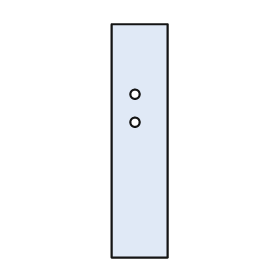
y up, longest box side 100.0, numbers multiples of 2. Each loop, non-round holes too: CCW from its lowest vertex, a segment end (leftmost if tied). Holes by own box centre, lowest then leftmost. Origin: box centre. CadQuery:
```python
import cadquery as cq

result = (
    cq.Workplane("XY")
    .moveTo(-12.0, -50.0)
    .lineTo(12.0, -50.0)
    .lineTo(12.0, 50.0)
    .lineTo(-12.0, 50.0)
    .close()
    .moveTo(-2.0, 8.0)
    .circle(2.0)
    .moveTo(-2.0, 20.0)
    .circle(2.0)
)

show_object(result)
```